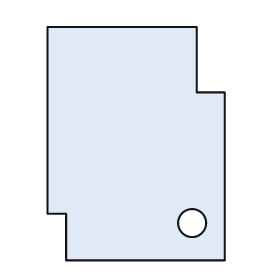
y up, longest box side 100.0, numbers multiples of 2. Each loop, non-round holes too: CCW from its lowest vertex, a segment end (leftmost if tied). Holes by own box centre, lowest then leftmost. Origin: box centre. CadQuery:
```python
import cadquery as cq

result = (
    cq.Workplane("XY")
    .moveTo(-30.0, -50.0)
    .lineTo(38.0, -50.0)
    .lineTo(38.0, 22.0)
    .lineTo(26.0, 22.0)
    .lineTo(26.0, 50.0)
    .lineTo(-38.0, 50.0)
    .lineTo(-38.0, -30.0)
    .lineTo(-30.0, -30.0)
    .close()
    .moveTo(24.0, -34.0)
    .circle(6.0)
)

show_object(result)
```